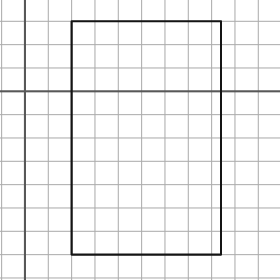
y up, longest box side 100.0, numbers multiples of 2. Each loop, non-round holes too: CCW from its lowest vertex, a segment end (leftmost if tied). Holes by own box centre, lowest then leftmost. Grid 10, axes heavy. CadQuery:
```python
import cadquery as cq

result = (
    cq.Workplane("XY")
    .moveTo(20.0, -70.0)
    .lineTo(84.0, -70.0)
    .lineTo(84.0, 30.0)
    .lineTo(20.0, 30.0)
    .close()
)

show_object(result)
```